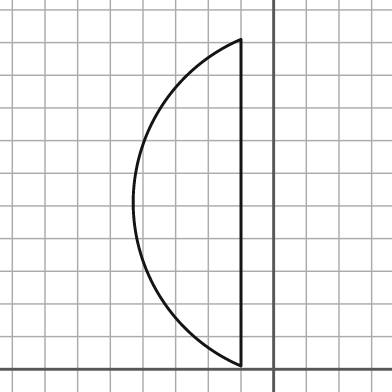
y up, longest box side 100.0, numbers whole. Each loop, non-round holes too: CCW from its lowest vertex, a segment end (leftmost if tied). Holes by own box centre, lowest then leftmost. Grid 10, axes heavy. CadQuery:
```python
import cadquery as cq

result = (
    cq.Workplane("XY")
    .moveTo(-10.0, 1.0)
    .lineTo(-10.0, 101.0)
    .threePointArc((-43.0, 51.0), (-10.0, 1.0))
    .close()
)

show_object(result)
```